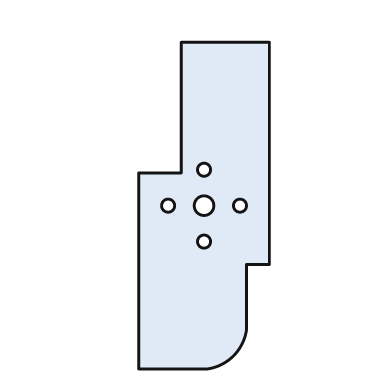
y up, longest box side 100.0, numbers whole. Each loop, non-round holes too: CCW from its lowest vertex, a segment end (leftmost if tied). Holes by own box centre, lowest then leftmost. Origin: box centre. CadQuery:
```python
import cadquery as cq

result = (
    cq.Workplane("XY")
    .moveTo(-20.0, -50.0)
    .lineTo(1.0, -50.0)
    .threePointArc((9.0, -46.0), (13.0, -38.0))
    .lineTo(13.0, -18.0)
    .lineTo(20.0, -18.0)
    .lineTo(20.0, 50.0)
    .lineTo(-7.0, 50.0)
    .lineTo(-7.0, 10.0)
    .lineTo(-20.0, 10.0)
    .close()
    .moveTo(0.0, -11.0)
    .circle(2.0)
    .moveTo(-11.0, 0.0)
    .circle(2.0)
    .moveTo(0.0, 0.0)
    .circle(3.0)
    .moveTo(11.0, 0.0)
    .circle(2.0)
    .moveTo(0.0, 11.0)
    .circle(2.0)
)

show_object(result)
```